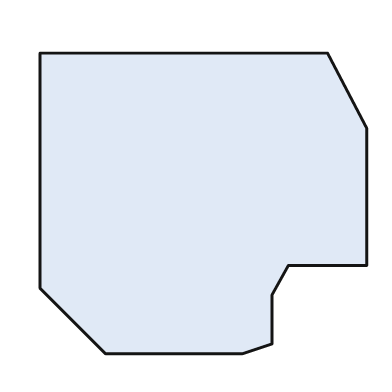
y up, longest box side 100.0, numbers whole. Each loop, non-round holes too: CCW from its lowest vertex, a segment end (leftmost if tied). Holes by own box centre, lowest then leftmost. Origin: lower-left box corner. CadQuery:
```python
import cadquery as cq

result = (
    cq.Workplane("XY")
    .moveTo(20.0, 0.0)
    .lineTo(62.0, 0.0)
    .lineTo(71.0, 3.0)
    .lineTo(71.0, 18.0)
    .lineTo(76.0, 27.0)
    .lineTo(100.0, 27.0)
    .lineTo(100.0, 69.0)
    .lineTo(88.0, 92.0)
    .lineTo(0.0, 92.0)
    .lineTo(0.0, 20.0)
    .close()
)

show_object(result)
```